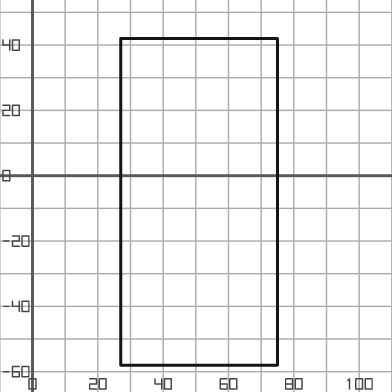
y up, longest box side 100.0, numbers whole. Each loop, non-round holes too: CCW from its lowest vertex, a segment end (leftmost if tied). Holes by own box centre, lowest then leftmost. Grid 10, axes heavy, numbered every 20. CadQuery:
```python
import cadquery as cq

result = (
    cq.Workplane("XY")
    .moveTo(27.0, -58.0)
    .lineTo(75.0, -58.0)
    .lineTo(75.0, 42.0)
    .lineTo(27.0, 42.0)
    .close()
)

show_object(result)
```